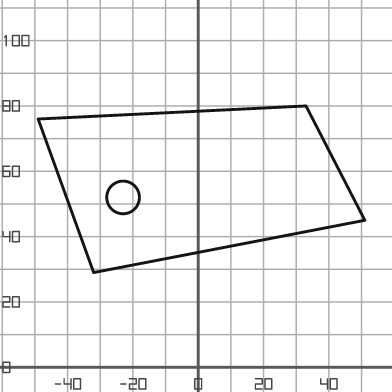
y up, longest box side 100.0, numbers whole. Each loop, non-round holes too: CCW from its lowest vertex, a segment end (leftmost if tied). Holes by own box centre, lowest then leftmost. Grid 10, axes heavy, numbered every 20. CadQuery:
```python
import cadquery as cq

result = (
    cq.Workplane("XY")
    .moveTo(-32.0, 29.0)
    .lineTo(51.0, 45.0)
    .lineTo(33.0, 80.0)
    .lineTo(-49.0, 76.0)
    .close()
    .moveTo(-23.0, 52.0)
    .circle(5.0)
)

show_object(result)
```